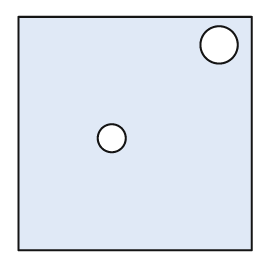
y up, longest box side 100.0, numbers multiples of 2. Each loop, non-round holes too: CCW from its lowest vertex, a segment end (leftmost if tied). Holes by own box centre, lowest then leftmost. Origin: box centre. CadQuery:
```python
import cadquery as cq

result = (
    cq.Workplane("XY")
    .moveTo(-50.0, -50.0)
    .lineTo(50.0, -50.0)
    .lineTo(50.0, 50.0)
    .lineTo(-50.0, 50.0)
    .close()
    .moveTo(-10.0, -2.0)
    .circle(6.0)
    .moveTo(36.0, 38.0)
    .circle(8.0)
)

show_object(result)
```